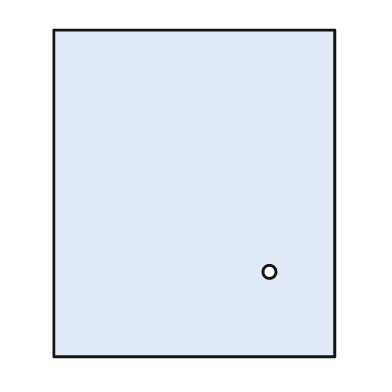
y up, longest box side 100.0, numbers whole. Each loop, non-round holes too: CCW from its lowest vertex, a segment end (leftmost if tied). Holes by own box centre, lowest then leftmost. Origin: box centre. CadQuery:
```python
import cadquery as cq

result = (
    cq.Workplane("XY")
    .moveTo(-43.0, -50.0)
    .lineTo(43.0, -50.0)
    .lineTo(43.0, 50.0)
    .lineTo(-43.0, 50.0)
    .close()
    .moveTo(23.0, -24.0)
    .circle(2.0)
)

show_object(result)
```